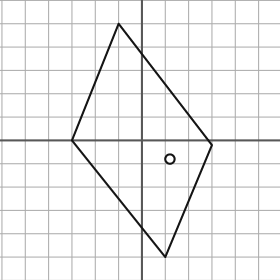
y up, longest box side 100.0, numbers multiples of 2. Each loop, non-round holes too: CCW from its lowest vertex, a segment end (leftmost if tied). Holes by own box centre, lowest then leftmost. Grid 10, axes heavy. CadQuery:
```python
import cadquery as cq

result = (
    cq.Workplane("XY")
    .moveTo(10.0, -50.0)
    .lineTo(30.0, -2.0)
    .lineTo(-10.0, 50.0)
    .lineTo(-30.0, 0.0)
    .close()
    .moveTo(12.0, -8.0)
    .circle(2.0)
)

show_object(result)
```